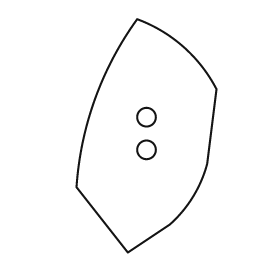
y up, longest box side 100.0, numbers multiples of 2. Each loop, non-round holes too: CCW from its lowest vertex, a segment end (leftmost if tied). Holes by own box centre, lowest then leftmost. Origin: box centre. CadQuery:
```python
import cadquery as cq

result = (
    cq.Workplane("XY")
    .moveTo(-8.0, -50.0)
    .lineTo(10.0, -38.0)
    .threePointArc((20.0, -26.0), (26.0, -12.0))
    .lineTo(30.0, 20.0)
    .threePointArc((16.0, 38.0), (-4.0, 50.0))
    .threePointArc((-22.0, 16.0), (-30.0, -22.0))
    .close()
    .moveTo(0.0, -6.0)
    .circle(4.0)
    .moveTo(0.0, 8.0)
    .circle(4.0)
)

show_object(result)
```